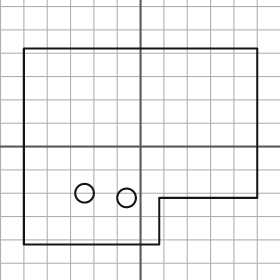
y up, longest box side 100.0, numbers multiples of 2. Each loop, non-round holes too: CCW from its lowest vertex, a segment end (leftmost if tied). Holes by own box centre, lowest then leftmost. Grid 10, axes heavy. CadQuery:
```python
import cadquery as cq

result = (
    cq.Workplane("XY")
    .moveTo(-50.0, -42.0)
    .lineTo(8.0, -42.0)
    .lineTo(8.0, -22.0)
    .lineTo(50.0, -22.0)
    .lineTo(50.0, 42.0)
    .lineTo(-50.0, 42.0)
    .close()
    .moveTo(-6.0, -22.0)
    .circle(4.0)
    .moveTo(-24.0, -20.0)
    .circle(4.0)
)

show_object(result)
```